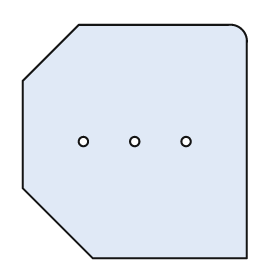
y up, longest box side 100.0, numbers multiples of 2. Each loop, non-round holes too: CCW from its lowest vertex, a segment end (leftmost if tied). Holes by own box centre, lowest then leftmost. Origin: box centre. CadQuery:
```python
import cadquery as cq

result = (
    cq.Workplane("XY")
    .moveTo(-18.0, -50.0)
    .lineTo(48.0, -50.0)
    .lineTo(48.0, 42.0)
    .threePointArc((46.0, 48.0), (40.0, 50.0))
    .lineTo(-24.0, 50.0)
    .lineTo(-48.0, 26.0)
    .lineTo(-48.0, -20.0)
    .close()
    .moveTo(-22.0, 0.0)
    .circle(2.0)
    .moveTo(0.0, 0.0)
    .circle(2.0)
    .moveTo(22.0, 0.0)
    .circle(2.0)
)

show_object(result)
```